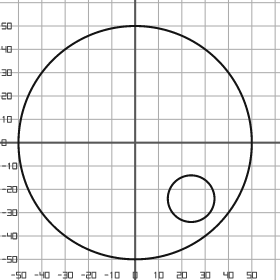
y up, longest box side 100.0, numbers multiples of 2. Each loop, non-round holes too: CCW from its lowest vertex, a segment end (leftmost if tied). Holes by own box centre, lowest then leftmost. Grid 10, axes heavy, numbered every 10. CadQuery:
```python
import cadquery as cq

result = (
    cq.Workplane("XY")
    .moveTo(0.0, 0.0)
    .circle(50.0)
    .moveTo(24.0, -24.0)
    .circle(10.0)
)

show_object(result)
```